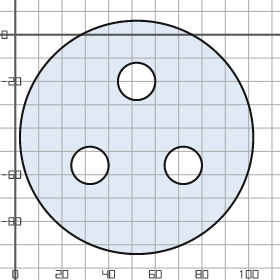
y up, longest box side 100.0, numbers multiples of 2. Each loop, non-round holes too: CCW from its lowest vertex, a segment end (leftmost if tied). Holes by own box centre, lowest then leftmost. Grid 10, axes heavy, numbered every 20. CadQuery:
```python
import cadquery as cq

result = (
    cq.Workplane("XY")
    .moveTo(52.0, -44.0)
    .circle(50.0)
    .moveTo(32.0, -56.0)
    .circle(8.0)
    .moveTo(72.0, -56.0)
    .circle(8.0)
    .moveTo(52.0, -20.0)
    .circle(8.0)
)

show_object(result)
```